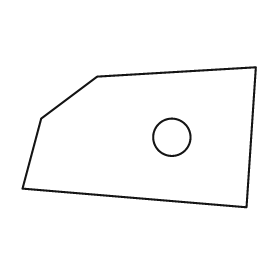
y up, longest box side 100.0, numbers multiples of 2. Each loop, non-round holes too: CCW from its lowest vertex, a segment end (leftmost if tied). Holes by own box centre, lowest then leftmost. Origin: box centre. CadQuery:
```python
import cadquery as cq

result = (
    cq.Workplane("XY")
    .moveTo(46.0, -30.0)
    .lineTo(50.0, 30.0)
    .lineTo(-18.0, 26.0)
    .lineTo(-42.0, 8.0)
    .lineTo(-50.0, -22.0)
    .close()
    .moveTo(14.0, 0.0)
    .circle(8.0)
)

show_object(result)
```